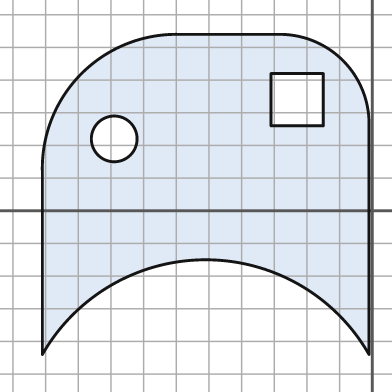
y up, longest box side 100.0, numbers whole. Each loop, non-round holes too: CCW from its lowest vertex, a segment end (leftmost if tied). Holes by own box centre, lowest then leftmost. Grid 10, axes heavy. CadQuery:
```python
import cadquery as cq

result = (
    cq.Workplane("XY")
    .moveTo(-101.0, -44.0)
    .threePointArc((-51.0, -15.0), (-1.0, -44.0))
    .lineTo(-1.0, 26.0)
    .threePointArc((-9.0, 46.0), (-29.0, 54.0))
    .lineTo(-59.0, 54.0)
    .threePointArc((-89.0, 42.0), (-101.0, 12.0))
    .close()
    .moveTo(-79.0, 22.0)
    .circle(7.0)
    .moveTo(-31.0, 26.0)
    .lineTo(-15.0, 26.0)
    .lineTo(-15.0, 42.0)
    .lineTo(-31.0, 42.0)
    .close()
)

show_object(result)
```